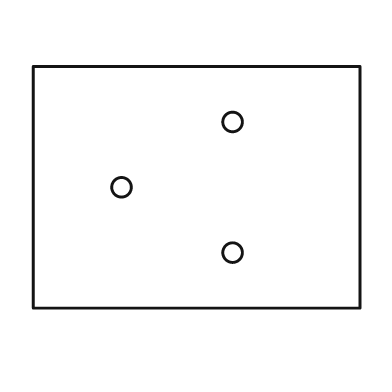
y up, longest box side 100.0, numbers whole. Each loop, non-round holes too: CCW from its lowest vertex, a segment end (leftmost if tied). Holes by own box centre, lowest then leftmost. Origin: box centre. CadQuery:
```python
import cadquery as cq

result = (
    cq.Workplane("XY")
    .moveTo(-50.0, -37.0)
    .lineTo(50.0, -37.0)
    .lineTo(50.0, 37.0)
    .lineTo(-50.0, 37.0)
    .close()
    .moveTo(11.0, -20.0)
    .circle(3.0)
    .moveTo(-23.0, 0.0)
    .circle(3.0)
    .moveTo(11.0, 20.0)
    .circle(3.0)
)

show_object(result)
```